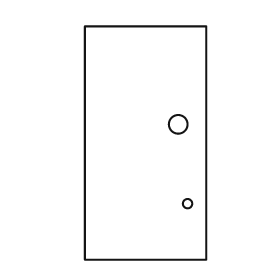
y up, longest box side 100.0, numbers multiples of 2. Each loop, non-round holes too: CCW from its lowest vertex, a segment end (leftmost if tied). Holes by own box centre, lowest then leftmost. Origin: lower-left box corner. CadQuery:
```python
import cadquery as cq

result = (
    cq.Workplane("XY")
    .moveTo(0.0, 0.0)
    .lineTo(52.0, 0.0)
    .lineTo(52.0, 100.0)
    .lineTo(0.0, 100.0)
    .close()
    .moveTo(44.0, 24.0)
    .circle(2.0)
    .moveTo(40.0, 58.0)
    .circle(4.0)
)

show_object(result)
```